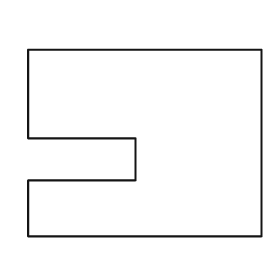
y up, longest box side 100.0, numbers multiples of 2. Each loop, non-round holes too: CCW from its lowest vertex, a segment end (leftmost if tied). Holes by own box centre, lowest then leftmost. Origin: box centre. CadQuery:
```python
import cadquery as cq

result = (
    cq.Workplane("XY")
    .moveTo(-50.0, -40.0)
    .lineTo(50.0, -40.0)
    .lineTo(50.0, 40.0)
    .lineTo(-50.0, 40.0)
    .lineTo(-50.0, 2.0)
    .lineTo(-4.0, 2.0)
    .lineTo(-4.0, -16.0)
    .lineTo(-50.0, -16.0)
    .close()
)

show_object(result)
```